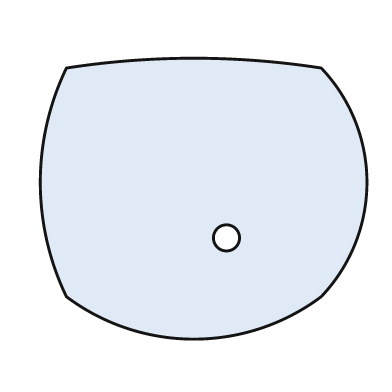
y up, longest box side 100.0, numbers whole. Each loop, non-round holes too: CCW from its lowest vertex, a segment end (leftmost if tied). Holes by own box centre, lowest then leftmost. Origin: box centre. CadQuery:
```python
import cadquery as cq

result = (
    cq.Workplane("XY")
    .moveTo(-42.0, -30.0)
    .threePointArc((-3.0, -43.0), (36.0, -30.0))
    .threePointArc((50.0, 5.0), (36.0, 40.0))
    .threePointArc((-3.0, 43.0), (-42.0, 40.0))
    .threePointArc((-50.0, 5.0), (-42.0, -30.0))
    .close()
    .moveTo(7.0, -12.0)
    .circle(4.0)
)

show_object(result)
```